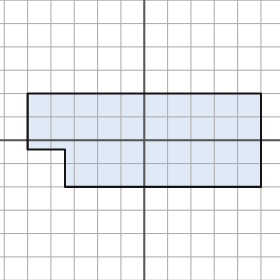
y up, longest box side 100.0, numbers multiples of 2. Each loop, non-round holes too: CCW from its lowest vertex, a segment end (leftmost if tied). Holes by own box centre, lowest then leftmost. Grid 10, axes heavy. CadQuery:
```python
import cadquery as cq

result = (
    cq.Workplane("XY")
    .moveTo(-34.0, -20.0)
    .lineTo(50.0, -20.0)
    .lineTo(50.0, 20.0)
    .lineTo(-50.0, 20.0)
    .lineTo(-50.0, -4.0)
    .lineTo(-34.0, -4.0)
    .close()
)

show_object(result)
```